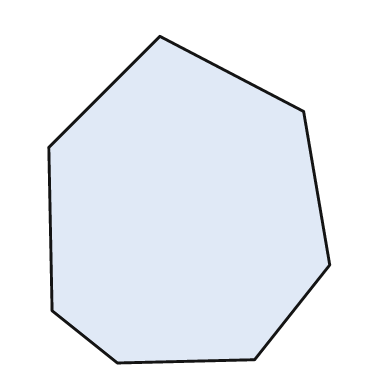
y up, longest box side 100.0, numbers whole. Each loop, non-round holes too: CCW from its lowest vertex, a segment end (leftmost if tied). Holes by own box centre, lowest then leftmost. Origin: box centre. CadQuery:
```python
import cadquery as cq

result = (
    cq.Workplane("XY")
    .moveTo(-22.0, -50.0)
    .lineTo(20.0, -49.0)
    .lineTo(43.0, -20.0)
    .lineTo(35.0, 27.0)
    .lineTo(-9.0, 50.0)
    .lineTo(-43.0, 16.0)
    .lineTo(-42.0, -34.0)
    .close()
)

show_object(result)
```